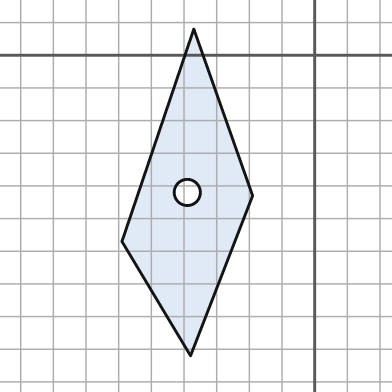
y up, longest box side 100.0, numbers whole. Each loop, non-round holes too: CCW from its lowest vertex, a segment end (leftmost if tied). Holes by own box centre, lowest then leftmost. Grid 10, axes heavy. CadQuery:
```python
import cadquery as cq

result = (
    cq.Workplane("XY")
    .moveTo(-38.0, -92.0)
    .lineTo(-19.0, -43.0)
    .lineTo(-37.0, 8.0)
    .lineTo(-59.0, -57.0)
    .close()
    .moveTo(-39.0, -42.0)
    .circle(4.0)
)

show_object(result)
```